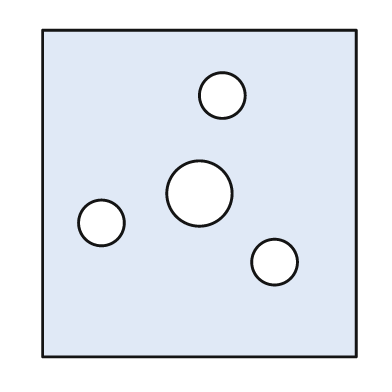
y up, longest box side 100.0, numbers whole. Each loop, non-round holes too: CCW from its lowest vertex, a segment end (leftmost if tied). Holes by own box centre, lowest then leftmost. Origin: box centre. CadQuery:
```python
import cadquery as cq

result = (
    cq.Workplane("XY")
    .moveTo(-48.0, -50.0)
    .lineTo(48.0, -50.0)
    .lineTo(48.0, 50.0)
    .lineTo(-48.0, 50.0)
    .close()
    .moveTo(23.0, -21.0)
    .circle(7.0)
    .moveTo(-30.0, -9.0)
    .circle(7.0)
    .moveTo(0.0, 0.0)
    .circle(10.0)
    .moveTo(7.0, 30.0)
    .circle(7.0)
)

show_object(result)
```